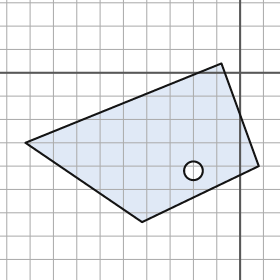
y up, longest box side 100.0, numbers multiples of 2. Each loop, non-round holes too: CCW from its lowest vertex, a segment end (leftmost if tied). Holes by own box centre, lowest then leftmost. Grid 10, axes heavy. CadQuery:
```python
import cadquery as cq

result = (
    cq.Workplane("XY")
    .moveTo(-42.0, -64.0)
    .lineTo(8.0, -40.0)
    .lineTo(-8.0, 4.0)
    .lineTo(-92.0, -30.0)
    .close()
    .moveTo(-20.0, -42.0)
    .circle(4.0)
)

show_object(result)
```